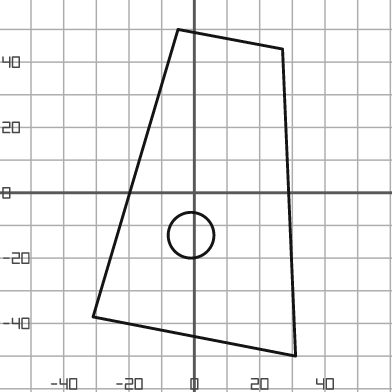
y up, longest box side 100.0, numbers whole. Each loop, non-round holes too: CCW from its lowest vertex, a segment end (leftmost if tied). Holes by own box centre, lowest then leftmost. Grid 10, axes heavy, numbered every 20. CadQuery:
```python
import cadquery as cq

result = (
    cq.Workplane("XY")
    .moveTo(31.0, -50.0)
    .lineTo(27.0, 44.0)
    .lineTo(-5.0, 50.0)
    .lineTo(-31.0, -38.0)
    .close()
    .moveTo(-1.0, -13.0)
    .circle(7.0)
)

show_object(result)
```